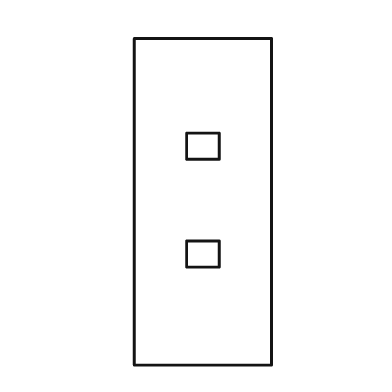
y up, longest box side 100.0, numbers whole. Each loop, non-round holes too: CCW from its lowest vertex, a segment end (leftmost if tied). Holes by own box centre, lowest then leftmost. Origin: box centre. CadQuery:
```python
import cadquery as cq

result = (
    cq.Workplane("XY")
    .moveTo(-21.0, -50.0)
    .lineTo(21.0, -50.0)
    .lineTo(21.0, 50.0)
    .lineTo(-21.0, 50.0)
    .close()
    .moveTo(-5.0, -20.0)
    .lineTo(5.0, -20.0)
    .lineTo(5.0, -12.0)
    .lineTo(-5.0, -12.0)
    .close()
    .moveTo(-5.0, 13.0)
    .lineTo(5.0, 13.0)
    .lineTo(5.0, 21.0)
    .lineTo(-5.0, 21.0)
    .close()
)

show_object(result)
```